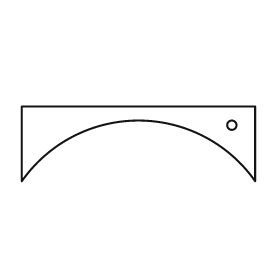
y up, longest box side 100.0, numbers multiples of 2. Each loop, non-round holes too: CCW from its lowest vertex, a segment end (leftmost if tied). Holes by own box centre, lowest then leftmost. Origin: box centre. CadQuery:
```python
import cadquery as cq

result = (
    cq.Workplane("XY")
    .moveTo(-50.0, -16.0)
    .threePointArc((0.0, 10.0), (50.0, -16.0))
    .lineTo(50.0, 16.0)
    .lineTo(-50.0, 16.0)
    .close()
    .moveTo(40.0, 8.0)
    .circle(2.0)
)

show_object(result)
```